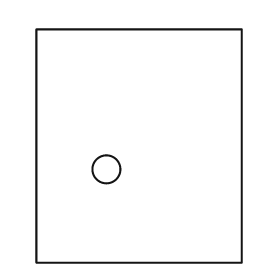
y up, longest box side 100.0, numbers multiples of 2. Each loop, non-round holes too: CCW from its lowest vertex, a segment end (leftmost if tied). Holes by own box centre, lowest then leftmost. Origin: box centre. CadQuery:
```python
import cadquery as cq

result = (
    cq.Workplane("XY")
    .moveTo(-44.0, -50.0)
    .lineTo(44.0, -50.0)
    .lineTo(44.0, 50.0)
    .lineTo(-44.0, 50.0)
    .close()
    .moveTo(-14.0, -10.0)
    .circle(6.0)
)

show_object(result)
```